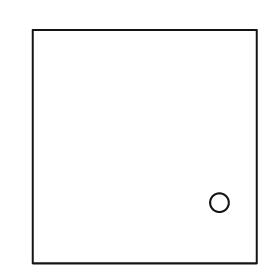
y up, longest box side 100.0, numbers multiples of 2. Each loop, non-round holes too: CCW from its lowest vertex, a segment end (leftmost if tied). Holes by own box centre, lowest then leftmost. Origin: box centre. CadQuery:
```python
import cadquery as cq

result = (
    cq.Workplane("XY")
    .moveTo(-48.0, -50.0)
    .lineTo(48.0, -50.0)
    .lineTo(48.0, 50.0)
    .lineTo(-48.0, 50.0)
    .close()
    .moveTo(32.0, -24.0)
    .circle(4.0)
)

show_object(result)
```